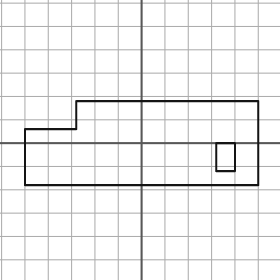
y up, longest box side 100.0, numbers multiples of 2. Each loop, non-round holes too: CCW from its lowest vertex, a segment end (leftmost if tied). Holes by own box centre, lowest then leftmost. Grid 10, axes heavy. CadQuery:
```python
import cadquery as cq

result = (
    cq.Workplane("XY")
    .moveTo(-50.0, -18.0)
    .lineTo(50.0, -18.0)
    .lineTo(50.0, 18.0)
    .lineTo(-28.0, 18.0)
    .lineTo(-28.0, 6.0)
    .lineTo(-50.0, 6.0)
    .close()
    .moveTo(32.0, -12.0)
    .lineTo(40.0, -12.0)
    .lineTo(40.0, 0.0)
    .lineTo(32.0, 0.0)
    .close()
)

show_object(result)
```